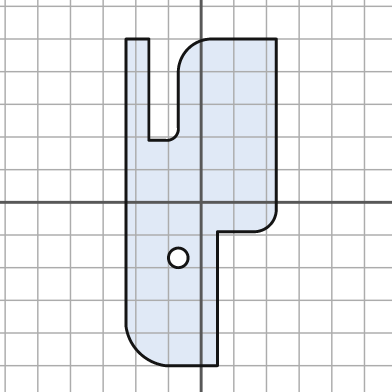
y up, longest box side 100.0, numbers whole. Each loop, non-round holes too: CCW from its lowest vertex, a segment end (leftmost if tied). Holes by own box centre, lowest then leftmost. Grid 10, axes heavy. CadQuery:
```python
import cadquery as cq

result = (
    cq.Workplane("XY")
    .moveTo(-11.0, -50.0)
    .lineTo(5.0, -50.0)
    .lineTo(5.0, -9.0)
    .lineTo(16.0, -9.0)
    .threePointArc((21.0, -7.0), (23.0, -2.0))
    .lineTo(23.0, 50.0)
    .lineTo(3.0, 50.0)
    .threePointArc((-4.0, 47.0), (-7.0, 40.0))
    .lineTo(-7.0, 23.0)
    .threePointArc((-8.0, 20.0), (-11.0, 19.0))
    .lineTo(-16.0, 19.0)
    .lineTo(-16.0, 50.0)
    .lineTo(-23.0, 50.0)
    .lineTo(-23.0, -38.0)
    .threePointArc((-19.0, -46.0), (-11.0, -50.0))
    .close()
    .moveTo(-7.0, -17.0)
    .circle(3.0)
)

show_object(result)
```